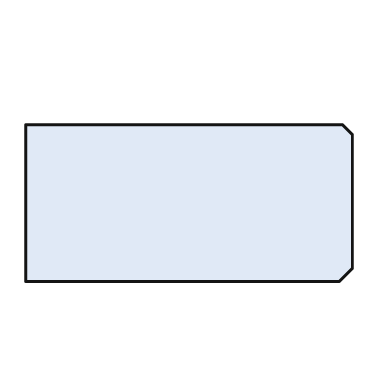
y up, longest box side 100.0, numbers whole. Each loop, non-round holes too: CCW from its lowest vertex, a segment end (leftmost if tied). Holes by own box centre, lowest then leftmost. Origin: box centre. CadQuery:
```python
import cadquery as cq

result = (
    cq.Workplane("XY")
    .moveTo(-50.0, -24.0)
    .lineTo(46.0, -24.0)
    .lineTo(50.0, -20.0)
    .lineTo(50.0, 21.0)
    .lineTo(47.0, 24.0)
    .lineTo(-50.0, 24.0)
    .close()
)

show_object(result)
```